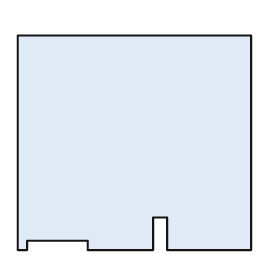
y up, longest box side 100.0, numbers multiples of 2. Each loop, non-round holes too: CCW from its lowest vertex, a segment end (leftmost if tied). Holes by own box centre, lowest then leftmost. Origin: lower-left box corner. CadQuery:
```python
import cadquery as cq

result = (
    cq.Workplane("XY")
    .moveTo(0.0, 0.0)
    .lineTo(4.0, 0.0)
    .lineTo(4.0, 4.0)
    .lineTo(30.0, 4.0)
    .lineTo(30.0, 0.0)
    .lineTo(58.0, 0.0)
    .lineTo(58.0, 14.0)
    .lineTo(64.0, 14.0)
    .lineTo(64.0, 0.0)
    .lineTo(100.0, 0.0)
    .lineTo(100.0, 92.0)
    .lineTo(0.0, 92.0)
    .close()
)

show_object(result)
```